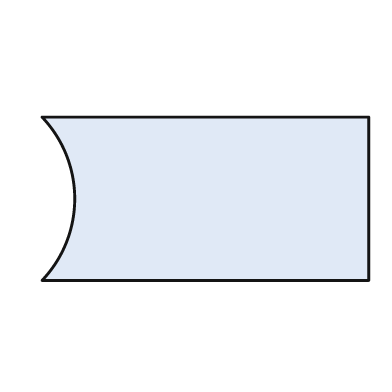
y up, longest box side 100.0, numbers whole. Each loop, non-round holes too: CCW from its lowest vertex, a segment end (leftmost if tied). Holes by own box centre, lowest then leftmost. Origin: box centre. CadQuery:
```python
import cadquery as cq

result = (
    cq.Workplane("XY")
    .moveTo(-50.0, -25.0)
    .lineTo(50.0, -25.0)
    .lineTo(50.0, 25.0)
    .lineTo(-50.0, 25.0)
    .threePointArc((-40.0, 0.0), (-50.0, -25.0))
    .close()
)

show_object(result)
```